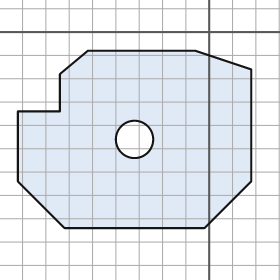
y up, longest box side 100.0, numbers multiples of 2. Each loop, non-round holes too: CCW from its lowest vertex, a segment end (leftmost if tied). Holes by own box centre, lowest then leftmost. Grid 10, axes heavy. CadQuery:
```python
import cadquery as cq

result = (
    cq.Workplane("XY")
    .moveTo(-62.0, -84.0)
    .lineTo(-2.0, -84.0)
    .lineTo(18.0, -64.0)
    .lineTo(18.0, -16.0)
    .lineTo(-6.0, -8.0)
    .lineTo(-52.0, -8.0)
    .lineTo(-64.0, -18.0)
    .lineTo(-64.0, -34.0)
    .lineTo(-82.0, -34.0)
    .lineTo(-82.0, -64.0)
    .close()
    .moveTo(-32.0, -46.0)
    .circle(8.0)
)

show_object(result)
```